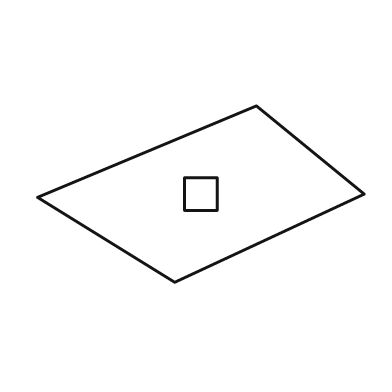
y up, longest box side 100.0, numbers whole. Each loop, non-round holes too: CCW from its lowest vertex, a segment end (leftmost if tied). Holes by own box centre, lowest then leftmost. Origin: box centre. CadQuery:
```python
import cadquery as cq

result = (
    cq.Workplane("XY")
    .moveTo(-8.0, -27.0)
    .lineTo(50.0, 0.0)
    .lineTo(17.0, 27.0)
    .lineTo(-50.0, -1.0)
    .close()
    .moveTo(-5.0, -5.0)
    .lineTo(5.0, -5.0)
    .lineTo(5.0, 5.0)
    .lineTo(-5.0, 5.0)
    .close()
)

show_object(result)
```